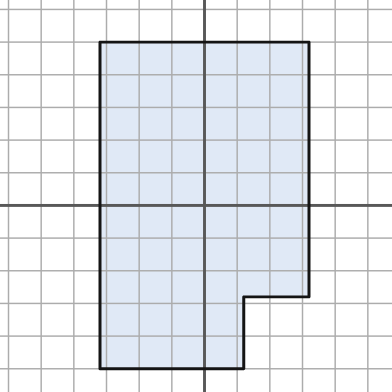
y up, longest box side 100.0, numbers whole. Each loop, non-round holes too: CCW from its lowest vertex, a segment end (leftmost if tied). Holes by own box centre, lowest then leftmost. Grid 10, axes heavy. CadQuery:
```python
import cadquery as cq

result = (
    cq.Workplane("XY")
    .moveTo(-32.0, -50.0)
    .lineTo(12.0, -50.0)
    .lineTo(12.0, -28.0)
    .lineTo(32.0, -28.0)
    .lineTo(32.0, 50.0)
    .lineTo(-32.0, 50.0)
    .close()
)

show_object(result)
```